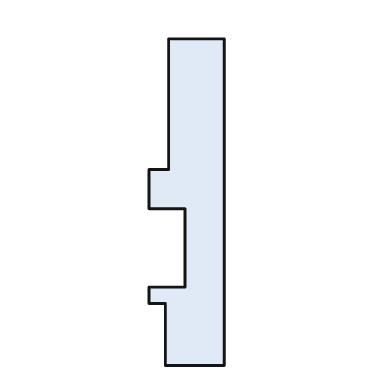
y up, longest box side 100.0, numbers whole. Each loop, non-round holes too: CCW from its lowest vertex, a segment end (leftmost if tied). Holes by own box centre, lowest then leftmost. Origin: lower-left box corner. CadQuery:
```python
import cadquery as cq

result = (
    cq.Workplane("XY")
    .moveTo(5.0, 0.0)
    .lineTo(23.0, 0.0)
    .lineTo(23.0, 100.0)
    .lineTo(6.0, 100.0)
    .lineTo(6.0, 60.0)
    .lineTo(0.0, 60.0)
    .lineTo(0.0, 48.0)
    .lineTo(11.0, 48.0)
    .lineTo(11.0, 24.0)
    .lineTo(0.0, 24.0)
    .lineTo(0.0, 19.0)
    .lineTo(5.0, 19.0)
    .close()
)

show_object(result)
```